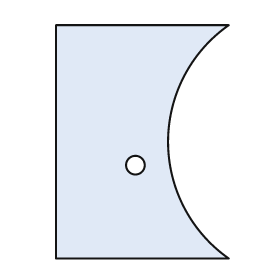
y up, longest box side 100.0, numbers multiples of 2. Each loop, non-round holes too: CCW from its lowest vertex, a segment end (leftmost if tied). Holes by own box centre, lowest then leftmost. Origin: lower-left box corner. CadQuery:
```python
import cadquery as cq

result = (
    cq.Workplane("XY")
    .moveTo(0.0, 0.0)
    .lineTo(74.0, 0.0)
    .threePointArc((48.0, 50.0), (74.0, 100.0))
    .lineTo(0.0, 100.0)
    .close()
    .moveTo(34.0, 40.0)
    .circle(4.0)
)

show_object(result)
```